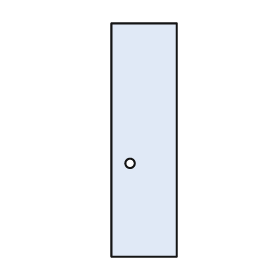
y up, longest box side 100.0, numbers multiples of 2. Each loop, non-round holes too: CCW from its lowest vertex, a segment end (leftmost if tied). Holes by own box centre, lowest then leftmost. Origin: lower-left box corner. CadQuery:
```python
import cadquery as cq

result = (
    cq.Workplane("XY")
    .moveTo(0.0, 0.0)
    .lineTo(28.0, 0.0)
    .lineTo(28.0, 100.0)
    .lineTo(0.0, 100.0)
    .close()
    .moveTo(8.0, 40.0)
    .circle(2.0)
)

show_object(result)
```